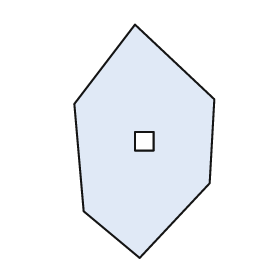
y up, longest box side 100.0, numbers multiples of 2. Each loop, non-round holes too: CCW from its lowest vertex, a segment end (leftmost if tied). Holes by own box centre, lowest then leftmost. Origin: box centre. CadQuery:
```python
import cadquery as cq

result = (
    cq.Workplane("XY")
    .moveTo(-2.0, -50.0)
    .lineTo(28.0, -18.0)
    .lineTo(30.0, 18.0)
    .lineTo(-4.0, 50.0)
    .lineTo(-30.0, 16.0)
    .lineTo(-26.0, -30.0)
    .close()
    .moveTo(-4.0, -4.0)
    .lineTo(4.0, -4.0)
    .lineTo(4.0, 4.0)
    .lineTo(-4.0, 4.0)
    .close()
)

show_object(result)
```